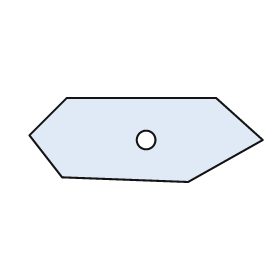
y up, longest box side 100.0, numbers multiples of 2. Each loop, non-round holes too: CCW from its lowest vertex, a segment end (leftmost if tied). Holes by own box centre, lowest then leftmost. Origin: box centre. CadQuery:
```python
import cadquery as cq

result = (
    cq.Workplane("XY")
    .moveTo(18.0, -18.0)
    .lineTo(50.0, 0.0)
    .lineTo(30.0, 18.0)
    .lineTo(-34.0, 18.0)
    .lineTo(-50.0, 2.0)
    .lineTo(-36.0, -16.0)
    .close()
    .moveTo(0.0, 0.0)
    .circle(4.0)
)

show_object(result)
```